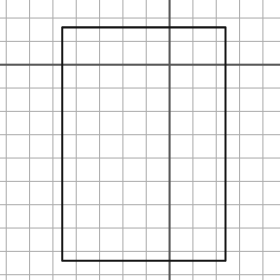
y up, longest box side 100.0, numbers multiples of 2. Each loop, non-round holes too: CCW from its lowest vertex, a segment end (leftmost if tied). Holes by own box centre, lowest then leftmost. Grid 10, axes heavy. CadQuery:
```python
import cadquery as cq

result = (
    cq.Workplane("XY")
    .moveTo(-46.0, -84.0)
    .lineTo(24.0, -84.0)
    .lineTo(24.0, 16.0)
    .lineTo(-46.0, 16.0)
    .close()
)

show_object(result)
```